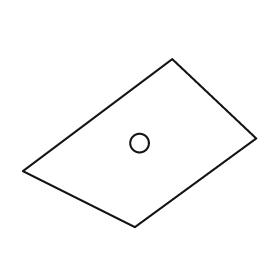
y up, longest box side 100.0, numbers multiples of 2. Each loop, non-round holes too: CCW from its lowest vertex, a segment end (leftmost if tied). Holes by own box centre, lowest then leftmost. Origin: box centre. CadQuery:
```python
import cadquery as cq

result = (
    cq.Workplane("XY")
    .moveTo(-2.0, -36.0)
    .lineTo(50.0, 2.0)
    .lineTo(14.0, 36.0)
    .lineTo(-50.0, -12.0)
    .close()
    .moveTo(0.0, 0.0)
    .circle(4.0)
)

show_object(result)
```